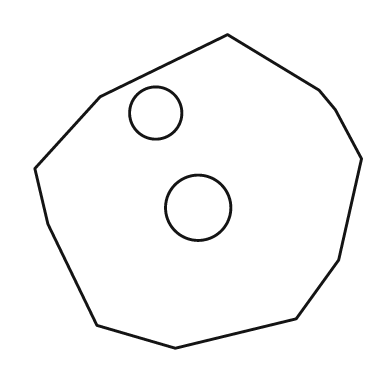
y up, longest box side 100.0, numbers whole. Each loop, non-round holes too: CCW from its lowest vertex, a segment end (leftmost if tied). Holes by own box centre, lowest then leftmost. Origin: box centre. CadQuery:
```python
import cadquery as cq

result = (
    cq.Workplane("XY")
    .moveTo(-7.0, -48.0)
    .lineTo(30.0, -39.0)
    .lineTo(43.0, -21.0)
    .lineTo(50.0, 10.0)
    .lineTo(42.0, 25.0)
    .lineTo(37.0, 31.0)
    .lineTo(9.0, 48.0)
    .lineTo(-30.0, 29.0)
    .lineTo(-50.0, 7.0)
    .lineTo(-46.0, -10.0)
    .lineTo(-31.0, -41.0)
    .close()
    .moveTo(0.0, -5.0)
    .circle(10.0)
    .moveTo(-13.0, 24.0)
    .circle(8.0)
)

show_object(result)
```